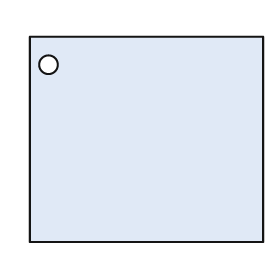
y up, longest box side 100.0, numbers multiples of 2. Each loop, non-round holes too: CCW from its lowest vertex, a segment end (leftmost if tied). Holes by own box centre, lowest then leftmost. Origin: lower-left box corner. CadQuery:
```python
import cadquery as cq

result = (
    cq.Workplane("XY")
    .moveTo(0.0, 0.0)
    .lineTo(100.0, 0.0)
    .lineTo(100.0, 88.0)
    .lineTo(0.0, 88.0)
    .close()
    .moveTo(8.0, 76.0)
    .circle(4.0)
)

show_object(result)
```